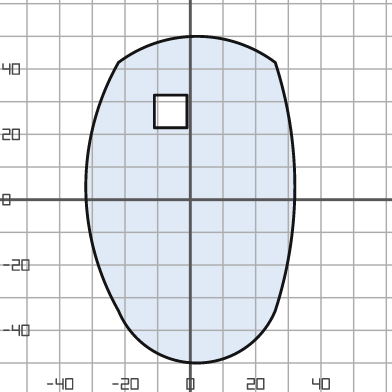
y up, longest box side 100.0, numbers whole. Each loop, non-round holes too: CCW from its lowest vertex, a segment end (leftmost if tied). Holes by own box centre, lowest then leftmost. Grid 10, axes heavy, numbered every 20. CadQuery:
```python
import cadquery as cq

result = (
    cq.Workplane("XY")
    .moveTo(-22.0, -34.0)
    .threePointArc((2.0, -50.0), (26.0, -34.0))
    .threePointArc((32.0, 4.0), (26.0, 42.0))
    .threePointArc((2.0, 50.0), (-22.0, 42.0))
    .threePointArc((-32.0, 4.0), (-22.0, -34.0))
    .close()
    .moveTo(-11.0, 22.0)
    .lineTo(-1.0, 22.0)
    .lineTo(-1.0, 32.0)
    .lineTo(-11.0, 32.0)
    .close()
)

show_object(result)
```